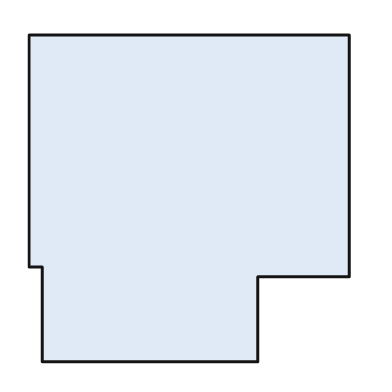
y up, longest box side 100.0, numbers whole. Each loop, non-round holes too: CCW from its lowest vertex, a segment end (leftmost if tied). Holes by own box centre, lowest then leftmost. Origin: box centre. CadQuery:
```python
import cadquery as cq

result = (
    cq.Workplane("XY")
    .moveTo(-45.0, -50.0)
    .lineTo(21.0, -50.0)
    .lineTo(21.0, -24.0)
    .lineTo(49.0, -24.0)
    .lineTo(49.0, 50.0)
    .lineTo(-49.0, 50.0)
    .lineTo(-49.0, -21.0)
    .lineTo(-45.0, -21.0)
    .close()
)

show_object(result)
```